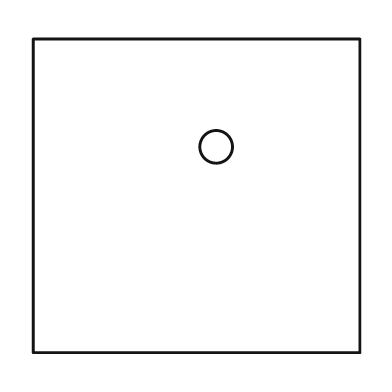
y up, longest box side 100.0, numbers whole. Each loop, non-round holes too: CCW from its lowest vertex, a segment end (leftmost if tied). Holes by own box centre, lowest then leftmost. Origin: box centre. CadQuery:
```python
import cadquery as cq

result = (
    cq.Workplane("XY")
    .moveTo(-50.0, -48.0)
    .lineTo(50.0, -48.0)
    .lineTo(50.0, 48.0)
    .lineTo(-50.0, 48.0)
    .close()
    .moveTo(6.0, 15.0)
    .circle(5.0)
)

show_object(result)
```